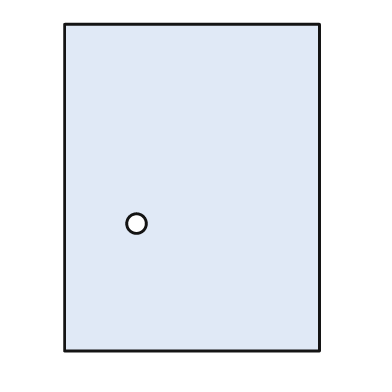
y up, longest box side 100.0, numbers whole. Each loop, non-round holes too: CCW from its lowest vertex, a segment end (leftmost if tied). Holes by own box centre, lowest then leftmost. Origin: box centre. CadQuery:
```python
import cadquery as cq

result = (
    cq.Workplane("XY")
    .moveTo(-39.0, -50.0)
    .lineTo(39.0, -50.0)
    .lineTo(39.0, 50.0)
    .lineTo(-39.0, 50.0)
    .close()
    .moveTo(-17.0, -11.0)
    .circle(3.0)
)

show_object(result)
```